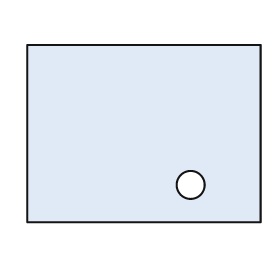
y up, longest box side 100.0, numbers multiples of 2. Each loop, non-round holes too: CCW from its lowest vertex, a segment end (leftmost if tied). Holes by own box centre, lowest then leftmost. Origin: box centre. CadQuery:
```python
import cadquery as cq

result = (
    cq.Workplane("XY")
    .moveTo(-50.0, -38.0)
    .lineTo(50.0, -38.0)
    .lineTo(50.0, 38.0)
    .lineTo(-50.0, 38.0)
    .close()
    .moveTo(20.0, -22.0)
    .circle(6.0)
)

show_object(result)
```